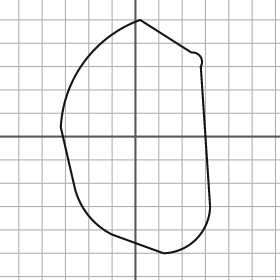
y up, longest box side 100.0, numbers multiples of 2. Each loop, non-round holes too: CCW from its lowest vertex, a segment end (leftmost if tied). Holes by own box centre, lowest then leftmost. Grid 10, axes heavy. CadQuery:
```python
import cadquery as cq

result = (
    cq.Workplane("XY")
    .moveTo(12.0, -50.0)
    .threePointArc((26.0, -44.0), (32.0, -30.0))
    .lineTo(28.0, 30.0)
    .threePointArc((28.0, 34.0), (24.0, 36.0))
    .lineTo(2.0, 50.0)
    .threePointArc((-22.0, 32.0), (-32.0, 4.0))
    .lineTo(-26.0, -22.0)
    .threePointArc((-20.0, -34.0), (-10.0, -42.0))
    .close()
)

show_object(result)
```